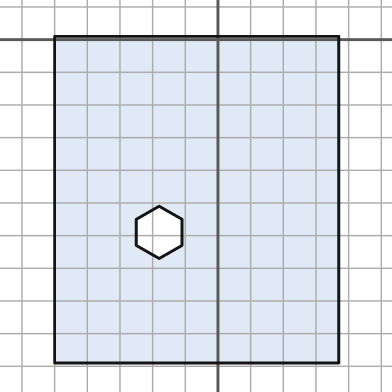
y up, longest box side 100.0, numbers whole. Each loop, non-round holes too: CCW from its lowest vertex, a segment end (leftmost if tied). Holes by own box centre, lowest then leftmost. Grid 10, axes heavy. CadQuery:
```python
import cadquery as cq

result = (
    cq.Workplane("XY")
    .moveTo(-50.0, -99.0)
    .lineTo(37.0, -99.0)
    .lineTo(37.0, 1.0)
    .lineTo(-50.0, 1.0)
    .close()
    .moveTo(-18.0, -67.0)
    .lineTo(-11.0, -63.0)
    .lineTo(-11.0, -55.0)
    .lineTo(-18.0, -51.0)
    .lineTo(-25.0, -55.0)
    .lineTo(-25.0, -63.0)
    .close()
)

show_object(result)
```